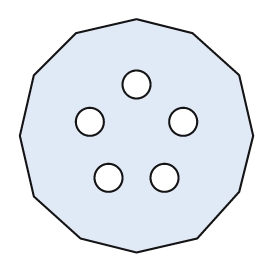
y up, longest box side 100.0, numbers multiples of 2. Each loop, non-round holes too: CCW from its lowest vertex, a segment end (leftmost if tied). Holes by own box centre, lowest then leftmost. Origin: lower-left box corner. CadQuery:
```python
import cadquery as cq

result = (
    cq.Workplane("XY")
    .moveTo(50.0, 0.0)
    .lineTo(76.0, 6.0)
    .lineTo(94.0, 26.0)
    .lineTo(100.0, 50.0)
    .lineTo(94.0, 76.0)
    .lineTo(74.0, 94.0)
    .lineTo(50.0, 100.0)
    .lineTo(24.0, 94.0)
    .lineTo(6.0, 76.0)
    .lineTo(0.0, 50.0)
    .lineTo(6.0, 24.0)
    .lineTo(26.0, 6.0)
    .close()
    .moveTo(38.0, 32.0)
    .circle(6.0)
    .moveTo(62.0, 32.0)
    .circle(6.0)
    .moveTo(30.0, 56.0)
    .circle(6.0)
    .moveTo(70.0, 56.0)
    .circle(6.0)
    .moveTo(50.0, 72.0)
    .circle(6.0)
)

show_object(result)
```